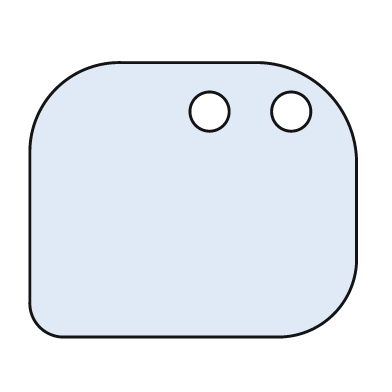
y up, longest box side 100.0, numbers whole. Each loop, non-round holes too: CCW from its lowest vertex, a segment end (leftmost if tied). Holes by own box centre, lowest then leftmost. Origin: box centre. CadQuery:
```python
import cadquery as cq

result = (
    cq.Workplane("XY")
    .moveTo(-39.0, -42.0)
    .lineTo(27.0, -42.0)
    .threePointArc((43.0, -35.0), (50.0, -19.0))
    .lineTo(50.0, 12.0)
    .threePointArc((41.0, 33.0), (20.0, 42.0))
    .lineTo(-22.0, 42.0)
    .threePointArc((-42.0, 34.0), (-50.0, 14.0))
    .lineTo(-50.0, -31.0)
    .threePointArc((-47.0, -39.0), (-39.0, -42.0))
    .close()
    .moveTo(5.0, 27.0)
    .circle(6.0)
    .moveTo(30.0, 27.0)
    .circle(6.0)
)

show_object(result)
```